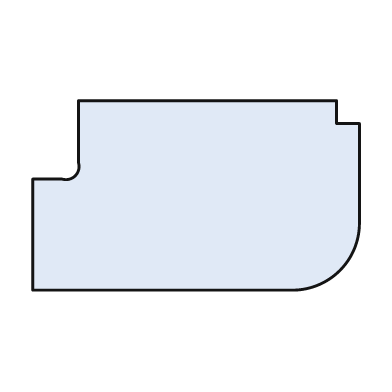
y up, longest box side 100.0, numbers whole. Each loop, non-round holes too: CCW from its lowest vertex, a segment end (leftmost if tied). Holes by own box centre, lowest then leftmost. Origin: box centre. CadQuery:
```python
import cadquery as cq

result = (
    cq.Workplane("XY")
    .moveTo(-50.0, -29.0)
    .lineTo(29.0, -29.0)
    .threePointArc((44.0, -23.0), (50.0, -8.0))
    .lineTo(50.0, 22.0)
    .lineTo(43.0, 22.0)
    .lineTo(43.0, 29.0)
    .lineTo(-36.0, 29.0)
    .lineTo(-36.0, 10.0)
    .threePointArc((-37.0, 6.0), (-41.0, 5.0))
    .lineTo(-50.0, 5.0)
    .close()
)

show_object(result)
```